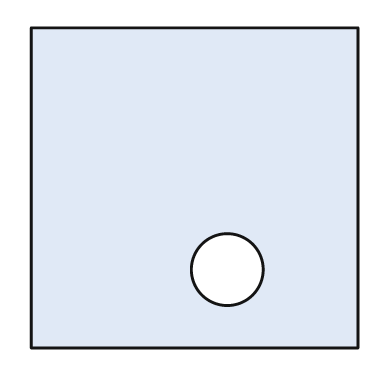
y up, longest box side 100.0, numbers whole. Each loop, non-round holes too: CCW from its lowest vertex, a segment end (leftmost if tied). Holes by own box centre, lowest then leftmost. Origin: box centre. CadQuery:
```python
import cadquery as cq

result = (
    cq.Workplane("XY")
    .moveTo(-50.0, -49.0)
    .lineTo(50.0, -49.0)
    .lineTo(50.0, 49.0)
    .lineTo(-50.0, 49.0)
    .close()
    .moveTo(10.0, -25.0)
    .circle(11.0)
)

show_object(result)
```